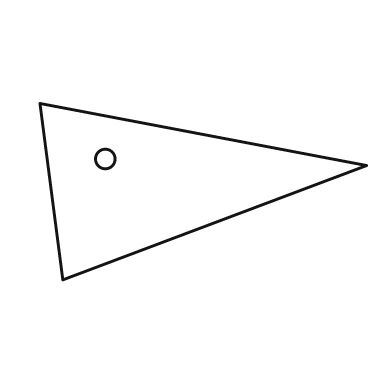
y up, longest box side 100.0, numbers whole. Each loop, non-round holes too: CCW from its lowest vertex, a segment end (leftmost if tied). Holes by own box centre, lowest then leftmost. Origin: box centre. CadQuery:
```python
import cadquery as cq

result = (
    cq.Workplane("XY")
    .moveTo(-43.0, -27.0)
    .lineTo(50.0, 8.0)
    .lineTo(-50.0, 27.0)
    .close()
    .moveTo(-30.0, 10.0)
    .circle(3.0)
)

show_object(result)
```